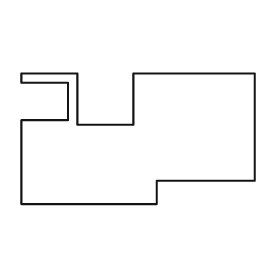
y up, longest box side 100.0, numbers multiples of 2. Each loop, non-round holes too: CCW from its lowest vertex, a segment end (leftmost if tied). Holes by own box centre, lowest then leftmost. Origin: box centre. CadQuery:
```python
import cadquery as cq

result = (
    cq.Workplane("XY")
    .moveTo(-50.0, -28.0)
    .lineTo(8.0, -28.0)
    .lineTo(8.0, -18.0)
    .lineTo(50.0, -18.0)
    .lineTo(50.0, 28.0)
    .lineTo(-2.0, 28.0)
    .lineTo(-2.0, 6.0)
    .lineTo(-26.0, 6.0)
    .lineTo(-26.0, 28.0)
    .lineTo(-50.0, 28.0)
    .lineTo(-50.0, 24.0)
    .lineTo(-30.0, 24.0)
    .lineTo(-30.0, 8.0)
    .lineTo(-50.0, 8.0)
    .close()
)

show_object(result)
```